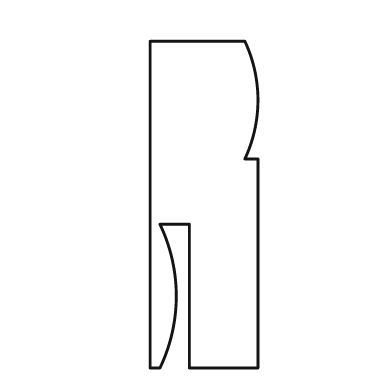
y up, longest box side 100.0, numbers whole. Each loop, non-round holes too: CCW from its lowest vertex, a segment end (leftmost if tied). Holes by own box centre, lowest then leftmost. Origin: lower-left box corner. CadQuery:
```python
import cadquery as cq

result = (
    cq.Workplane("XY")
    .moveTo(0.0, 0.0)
    .lineTo(3.0, 0.0)
    .threePointArc((8.0, 22.0), (3.0, 44.0))
    .lineTo(12.0, 44.0)
    .lineTo(12.0, 0.0)
    .lineTo(33.0, 0.0)
    .lineTo(33.0, 64.0)
    .lineTo(29.0, 64.0)
    .threePointArc((33.0, 82.0), (29.0, 100.0))
    .lineTo(0.0, 100.0)
    .close()
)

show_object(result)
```